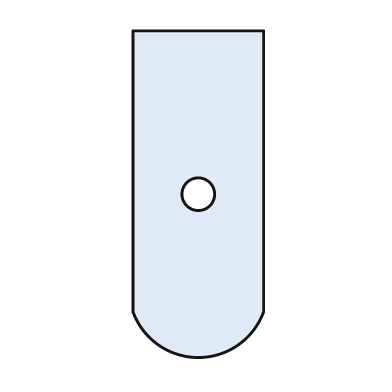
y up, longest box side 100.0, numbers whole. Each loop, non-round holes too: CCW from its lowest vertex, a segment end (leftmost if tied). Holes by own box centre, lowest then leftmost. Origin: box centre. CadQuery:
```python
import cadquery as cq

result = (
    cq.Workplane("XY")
    .moveTo(-20.0, -36.0)
    .threePointArc((0.0, -50.0), (20.0, -36.0))
    .lineTo(20.0, 50.0)
    .lineTo(-20.0, 50.0)
    .close()
    .moveTo(0.0, 0.0)
    .circle(5.0)
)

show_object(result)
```